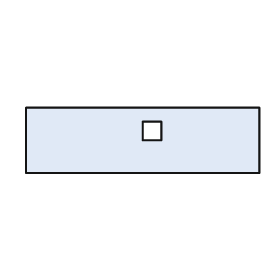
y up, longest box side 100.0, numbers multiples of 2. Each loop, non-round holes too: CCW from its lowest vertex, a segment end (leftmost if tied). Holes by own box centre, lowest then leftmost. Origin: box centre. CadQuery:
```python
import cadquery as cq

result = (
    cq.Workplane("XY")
    .moveTo(-50.0, -14.0)
    .lineTo(50.0, -14.0)
    .lineTo(50.0, 14.0)
    .lineTo(-50.0, 14.0)
    .close()
    .moveTo(0.0, 0.0)
    .lineTo(8.0, 0.0)
    .lineTo(8.0, 8.0)
    .lineTo(0.0, 8.0)
    .close()
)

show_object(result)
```